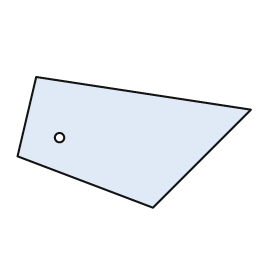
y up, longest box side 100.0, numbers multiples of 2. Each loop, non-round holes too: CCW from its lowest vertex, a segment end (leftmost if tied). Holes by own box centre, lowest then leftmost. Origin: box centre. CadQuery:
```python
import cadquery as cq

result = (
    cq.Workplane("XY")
    .moveTo(8.0, -28.0)
    .lineTo(50.0, 14.0)
    .lineTo(-42.0, 28.0)
    .lineTo(-50.0, -6.0)
    .close()
    .moveTo(-32.0, 2.0)
    .circle(2.0)
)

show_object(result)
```